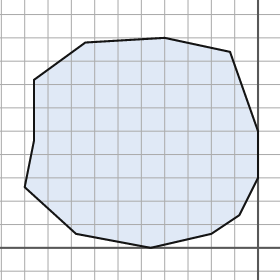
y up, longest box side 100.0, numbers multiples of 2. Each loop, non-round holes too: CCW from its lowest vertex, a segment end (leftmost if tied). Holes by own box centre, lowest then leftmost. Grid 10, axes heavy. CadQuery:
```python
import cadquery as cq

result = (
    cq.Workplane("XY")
    .moveTo(-46.0, 0.0)
    .lineTo(-20.0, 6.0)
    .lineTo(-8.0, 14.0)
    .lineTo(0.0, 30.0)
    .lineTo(0.0, 50.0)
    .lineTo(-12.0, 84.0)
    .lineTo(-40.0, 90.0)
    .lineTo(-74.0, 88.0)
    .lineTo(-96.0, 72.0)
    .lineTo(-96.0, 46.0)
    .lineTo(-100.0, 26.0)
    .lineTo(-78.0, 6.0)
    .close()
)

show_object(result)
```